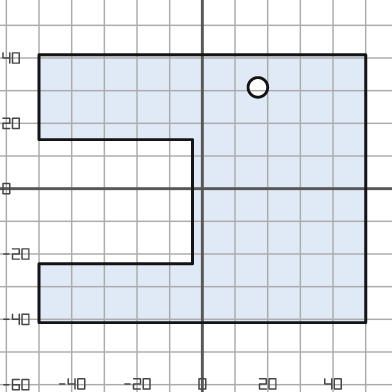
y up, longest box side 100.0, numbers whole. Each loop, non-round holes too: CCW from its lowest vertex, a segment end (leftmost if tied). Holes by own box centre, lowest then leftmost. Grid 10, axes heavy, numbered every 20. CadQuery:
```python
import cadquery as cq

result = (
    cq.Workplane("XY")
    .moveTo(-50.0, -41.0)
    .lineTo(50.0, -41.0)
    .lineTo(50.0, 41.0)
    .lineTo(-50.0, 41.0)
    .lineTo(-50.0, 15.0)
    .lineTo(-3.0, 15.0)
    .lineTo(-3.0, -23.0)
    .lineTo(-50.0, -23.0)
    .close()
    .moveTo(17.0, 31.0)
    .circle(3.0)
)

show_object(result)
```